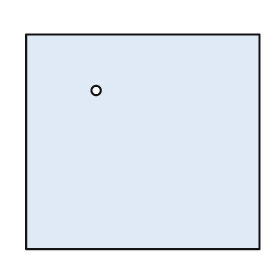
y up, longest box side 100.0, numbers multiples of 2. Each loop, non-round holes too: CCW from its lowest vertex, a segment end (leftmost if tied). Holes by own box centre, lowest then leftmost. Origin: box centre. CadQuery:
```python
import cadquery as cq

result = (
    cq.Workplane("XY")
    .moveTo(-50.0, -46.0)
    .lineTo(50.0, -46.0)
    .lineTo(50.0, 46.0)
    .lineTo(-50.0, 46.0)
    .close()
    .moveTo(-20.0, 22.0)
    .circle(2.0)
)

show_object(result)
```